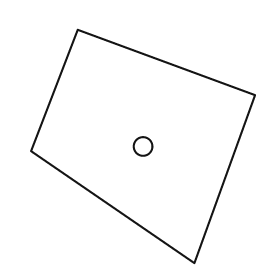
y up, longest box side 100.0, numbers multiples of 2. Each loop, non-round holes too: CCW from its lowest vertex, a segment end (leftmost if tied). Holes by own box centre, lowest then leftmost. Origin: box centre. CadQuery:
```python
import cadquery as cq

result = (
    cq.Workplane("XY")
    .moveTo(22.0, -50.0)
    .lineTo(48.0, 22.0)
    .lineTo(-28.0, 50.0)
    .lineTo(-48.0, -2.0)
    .close()
    .moveTo(0.0, 0.0)
    .circle(4.0)
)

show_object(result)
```